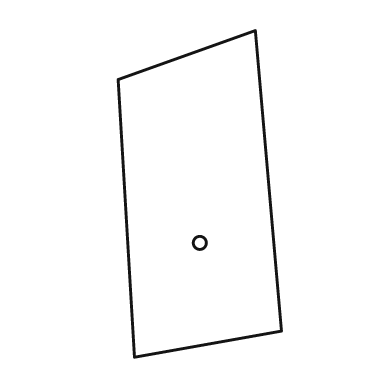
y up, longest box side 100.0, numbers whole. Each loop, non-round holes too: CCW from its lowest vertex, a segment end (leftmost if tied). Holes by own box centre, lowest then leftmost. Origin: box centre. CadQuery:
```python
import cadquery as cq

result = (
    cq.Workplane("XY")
    .moveTo(-20.0, -50.0)
    .lineTo(25.0, -42.0)
    .lineTo(17.0, 50.0)
    .lineTo(-25.0, 35.0)
    .close()
    .moveTo(0.0, -15.0)
    .circle(2.0)
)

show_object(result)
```